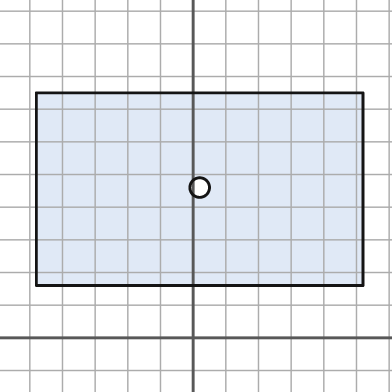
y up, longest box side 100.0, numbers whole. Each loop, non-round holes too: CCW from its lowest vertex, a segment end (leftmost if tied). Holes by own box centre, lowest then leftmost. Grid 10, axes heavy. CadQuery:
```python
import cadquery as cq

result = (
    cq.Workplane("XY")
    .moveTo(-48.0, 16.0)
    .lineTo(52.0, 16.0)
    .lineTo(52.0, 75.0)
    .lineTo(-48.0, 75.0)
    .close()
    .moveTo(2.0, 46.0)
    .circle(3.0)
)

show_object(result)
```